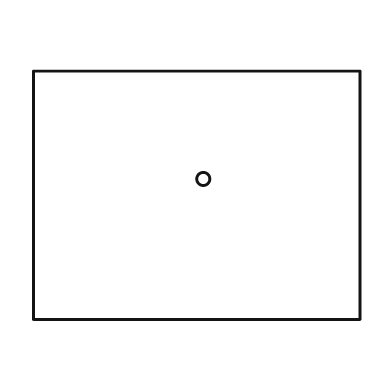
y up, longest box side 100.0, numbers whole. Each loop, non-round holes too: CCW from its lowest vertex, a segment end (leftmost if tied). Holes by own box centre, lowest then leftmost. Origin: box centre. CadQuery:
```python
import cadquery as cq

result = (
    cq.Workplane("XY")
    .moveTo(-50.0, -38.0)
    .lineTo(50.0, -38.0)
    .lineTo(50.0, 38.0)
    .lineTo(-50.0, 38.0)
    .close()
    .moveTo(2.0, 5.0)
    .circle(2.0)
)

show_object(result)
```